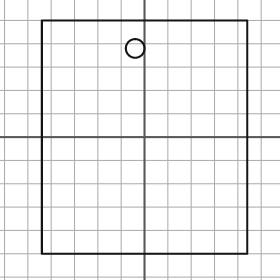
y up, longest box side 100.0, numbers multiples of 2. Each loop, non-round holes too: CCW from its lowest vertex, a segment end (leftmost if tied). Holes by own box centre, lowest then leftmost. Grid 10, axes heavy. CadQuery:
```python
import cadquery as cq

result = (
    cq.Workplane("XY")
    .moveTo(-44.0, -50.0)
    .lineTo(44.0, -50.0)
    .lineTo(44.0, 50.0)
    .lineTo(-44.0, 50.0)
    .close()
    .moveTo(-4.0, 38.0)
    .circle(4.0)
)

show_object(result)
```